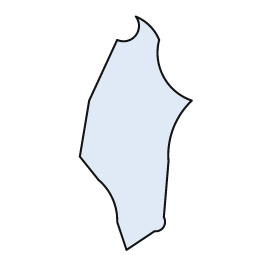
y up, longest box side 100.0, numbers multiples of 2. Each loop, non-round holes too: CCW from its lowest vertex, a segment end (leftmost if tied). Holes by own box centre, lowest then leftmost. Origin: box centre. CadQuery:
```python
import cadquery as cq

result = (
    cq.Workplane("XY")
    .moveTo(-4.0, -50.0)
    .lineTo(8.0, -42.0)
    .threePointArc((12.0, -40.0), (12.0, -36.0))
    .lineTo(14.0, -12.0)
    .threePointArc((16.0, 2.0), (24.0, 14.0))
    .threePointArc((12.0, 24.0), (10.0, 40.0))
    .threePointArc((6.0, 46.0), (0.0, 50.0))
    .threePointArc((0.0, 42.0), (-8.0, 40.0))
    .lineTo(-20.0, 14.0)
    .lineTo(-24.0, -10.0)
    .lineTo(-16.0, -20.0)
    .threePointArc((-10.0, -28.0), (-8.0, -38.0))
    .close()
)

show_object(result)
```